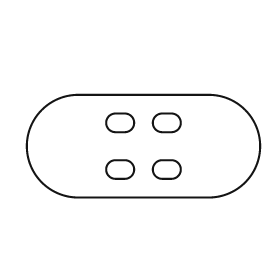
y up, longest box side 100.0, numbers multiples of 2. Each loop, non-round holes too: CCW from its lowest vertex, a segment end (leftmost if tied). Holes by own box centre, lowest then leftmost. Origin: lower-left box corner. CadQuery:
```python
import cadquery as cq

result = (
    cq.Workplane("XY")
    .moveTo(22.0, 0.0)
    .lineTo(78.0, 0.0)
    .threePointArc((100.0, 22.0), (78.0, 44.0))
    .lineTo(22.0, 44.0)
    .threePointArc((0.0, 22.0), (22.0, 0.0))
    .close()
    .moveTo(38.0, 8.0)
    .lineTo(42.0, 8.0)
    .threePointArc((46.0, 12.0), (42.0, 16.0))
    .lineTo(38.0, 16.0)
    .threePointArc((34.0, 12.0), (38.0, 8.0))
    .close()
    .moveTo(58.0, 8.0)
    .lineTo(62.0, 8.0)
    .threePointArc((66.0, 12.0), (62.0, 16.0))
    .lineTo(58.0, 16.0)
    .threePointArc((54.0, 12.0), (58.0, 8.0))
    .close()
    .moveTo(38.0, 28.0)
    .lineTo(42.0, 28.0)
    .threePointArc((46.0, 32.0), (42.0, 36.0))
    .lineTo(38.0, 36.0)
    .threePointArc((34.0, 32.0), (38.0, 28.0))
    .close()
    .moveTo(58.0, 28.0)
    .lineTo(62.0, 28.0)
    .threePointArc((66.0, 32.0), (62.0, 36.0))
    .lineTo(58.0, 36.0)
    .threePointArc((54.0, 32.0), (58.0, 28.0))
    .close()
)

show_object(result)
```